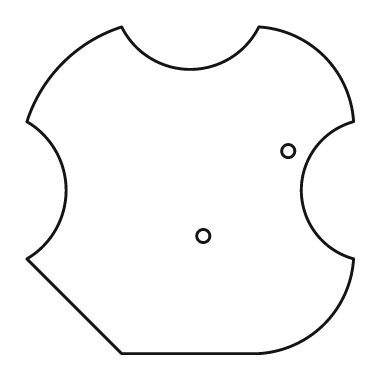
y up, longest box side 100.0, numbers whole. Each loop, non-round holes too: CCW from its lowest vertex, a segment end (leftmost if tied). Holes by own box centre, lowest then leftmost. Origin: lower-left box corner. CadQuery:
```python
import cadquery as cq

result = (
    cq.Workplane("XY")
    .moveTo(29.0, 0.0)
    .lineTo(71.0, 0.0)
    .threePointArc((91.0, 9.0), (100.0, 29.0))
    .threePointArc((84.0, 50.0), (100.0, 71.0))
    .threePointArc((91.0, 91.0), (71.0, 100.0))
    .threePointArc((50.0, 87.0), (29.0, 100.0))
    .threePointArc((11.0, 89.0), (0.0, 71.0))
    .threePointArc((12.0, 50.0), (0.0, 29.0))
    .close()
    .moveTo(54.0, 36.0)
    .circle(2.0)
    .moveTo(80.0, 62.0)
    .circle(2.0)
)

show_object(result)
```